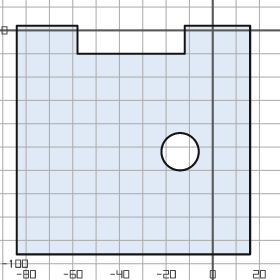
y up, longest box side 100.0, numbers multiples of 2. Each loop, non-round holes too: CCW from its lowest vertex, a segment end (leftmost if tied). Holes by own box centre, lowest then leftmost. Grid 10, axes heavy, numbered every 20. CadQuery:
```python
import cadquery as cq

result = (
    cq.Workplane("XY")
    .moveTo(-84.0, -96.0)
    .lineTo(16.0, -96.0)
    .lineTo(16.0, 2.0)
    .lineTo(-12.0, 2.0)
    .lineTo(-12.0, -10.0)
    .lineTo(-58.0, -10.0)
    .lineTo(-58.0, 2.0)
    .lineTo(-84.0, 2.0)
    .close()
    .moveTo(-14.0, -52.0)
    .circle(8.0)
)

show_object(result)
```